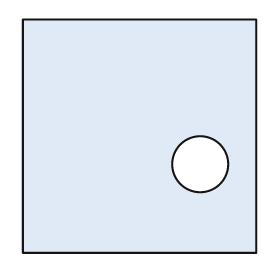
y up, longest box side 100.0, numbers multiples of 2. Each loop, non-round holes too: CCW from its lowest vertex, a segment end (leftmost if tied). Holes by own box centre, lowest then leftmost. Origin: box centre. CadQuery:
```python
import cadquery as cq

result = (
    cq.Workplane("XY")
    .moveTo(-50.0, -50.0)
    .lineTo(50.0, -50.0)
    .lineTo(50.0, 50.0)
    .lineTo(-50.0, 50.0)
    .close()
    .moveTo(26.0, -12.0)
    .circle(12.0)
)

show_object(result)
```